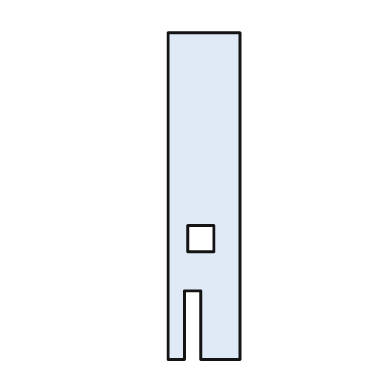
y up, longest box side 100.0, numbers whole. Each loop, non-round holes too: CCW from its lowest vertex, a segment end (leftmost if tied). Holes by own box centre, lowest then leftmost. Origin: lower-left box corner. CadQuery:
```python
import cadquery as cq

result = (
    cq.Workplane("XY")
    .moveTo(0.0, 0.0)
    .lineTo(5.0, 0.0)
    .lineTo(5.0, 21.0)
    .lineTo(10.0, 21.0)
    .lineTo(10.0, 0.0)
    .lineTo(22.0, 0.0)
    .lineTo(22.0, 100.0)
    .lineTo(0.0, 100.0)
    .close()
    .moveTo(6.0, 33.0)
    .lineTo(14.0, 33.0)
    .lineTo(14.0, 41.0)
    .lineTo(6.0, 41.0)
    .close()
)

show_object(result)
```